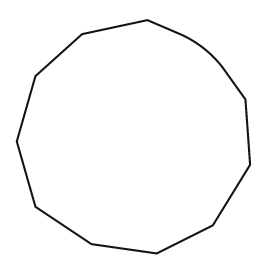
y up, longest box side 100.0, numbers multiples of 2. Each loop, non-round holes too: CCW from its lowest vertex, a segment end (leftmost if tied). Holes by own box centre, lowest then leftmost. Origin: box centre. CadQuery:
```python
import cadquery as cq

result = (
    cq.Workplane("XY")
    .moveTo(10.0, -50.0)
    .lineTo(34.0, -38.0)
    .lineTo(50.0, -12.0)
    .lineTo(48.0, 16.0)
    .lineTo(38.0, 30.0)
    .threePointArc((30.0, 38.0), (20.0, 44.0))
    .lineTo(6.0, 50.0)
    .lineTo(-22.0, 44.0)
    .lineTo(-42.0, 26.0)
    .lineTo(-50.0, -2.0)
    .lineTo(-42.0, -30.0)
    .lineTo(-18.0, -46.0)
    .close()
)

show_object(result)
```